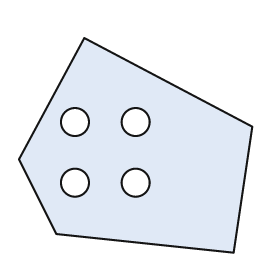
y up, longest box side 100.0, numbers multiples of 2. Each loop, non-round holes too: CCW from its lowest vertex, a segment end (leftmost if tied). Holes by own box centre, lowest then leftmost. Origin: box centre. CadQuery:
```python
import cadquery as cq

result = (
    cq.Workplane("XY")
    .moveTo(42.0, -46.0)
    .lineTo(50.0, 8.0)
    .lineTo(-22.0, 46.0)
    .lineTo(-50.0, -6.0)
    .lineTo(-34.0, -38.0)
    .close()
    .moveTo(-26.0, -16.0)
    .circle(6.0)
    .moveTo(0.0, -16.0)
    .circle(6.0)
    .moveTo(-26.0, 10.0)
    .circle(6.0)
    .moveTo(0.0, 10.0)
    .circle(6.0)
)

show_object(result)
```